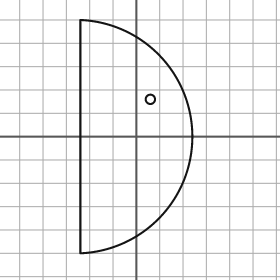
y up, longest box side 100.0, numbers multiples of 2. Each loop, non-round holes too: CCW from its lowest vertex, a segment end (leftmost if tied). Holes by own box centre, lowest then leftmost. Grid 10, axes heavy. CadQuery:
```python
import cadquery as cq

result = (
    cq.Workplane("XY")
    .moveTo(-24.0, -50.0)
    .threePointArc((24.0, 0.0), (-24.0, 50.0))
    .close()
    .moveTo(6.0, 16.0)
    .circle(2.0)
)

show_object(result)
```